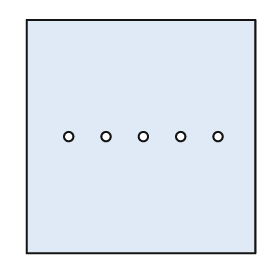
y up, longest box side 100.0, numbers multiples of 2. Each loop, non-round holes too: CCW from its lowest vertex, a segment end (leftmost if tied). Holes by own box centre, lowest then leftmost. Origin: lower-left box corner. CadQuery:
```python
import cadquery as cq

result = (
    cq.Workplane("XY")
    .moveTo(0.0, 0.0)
    .lineTo(98.0, 0.0)
    .lineTo(98.0, 100.0)
    .lineTo(0.0, 100.0)
    .close()
    .moveTo(18.0, 50.0)
    .circle(2.0)
    .moveTo(34.0, 50.0)
    .circle(2.0)
    .moveTo(50.0, 50.0)
    .circle(2.0)
    .moveTo(66.0, 50.0)
    .circle(2.0)
    .moveTo(82.0, 50.0)
    .circle(2.0)
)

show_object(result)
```